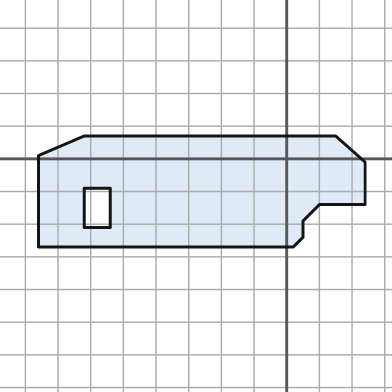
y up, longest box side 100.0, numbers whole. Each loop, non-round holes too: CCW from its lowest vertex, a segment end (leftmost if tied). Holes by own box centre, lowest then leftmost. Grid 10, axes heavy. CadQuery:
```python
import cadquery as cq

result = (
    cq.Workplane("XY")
    .moveTo(-76.0, -27.0)
    .lineTo(2.0, -27.0)
    .lineTo(5.0, -24.0)
    .lineTo(5.0, -19.0)
    .lineTo(10.0, -14.0)
    .lineTo(24.0, -14.0)
    .lineTo(24.0, -1.0)
    .lineTo(15.0, 7.0)
    .lineTo(-62.0, 7.0)
    .lineTo(-76.0, 1.0)
    .close()
    .moveTo(-62.0, -21.0)
    .lineTo(-54.0, -21.0)
    .lineTo(-54.0, -9.0)
    .lineTo(-62.0, -9.0)
    .close()
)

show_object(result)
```